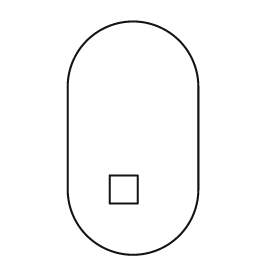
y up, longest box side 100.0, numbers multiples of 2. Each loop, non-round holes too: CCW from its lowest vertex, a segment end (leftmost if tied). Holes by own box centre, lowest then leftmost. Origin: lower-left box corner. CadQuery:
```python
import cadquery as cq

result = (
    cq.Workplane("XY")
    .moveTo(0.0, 28.0)
    .threePointArc((28.0, 0.0), (56.0, 28.0))
    .lineTo(56.0, 72.0)
    .threePointArc((28.0, 100.0), (0.0, 72.0))
    .close()
    .moveTo(18.0, 22.0)
    .lineTo(30.0, 22.0)
    .lineTo(30.0, 34.0)
    .lineTo(18.0, 34.0)
    .close()
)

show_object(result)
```